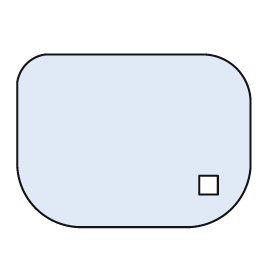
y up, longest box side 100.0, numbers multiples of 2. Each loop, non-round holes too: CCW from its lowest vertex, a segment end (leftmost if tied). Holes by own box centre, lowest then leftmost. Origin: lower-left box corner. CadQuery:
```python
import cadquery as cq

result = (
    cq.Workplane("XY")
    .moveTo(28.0, 0.0)
    .lineTo(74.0, 0.0)
    .threePointArc((92.0, 8.0), (100.0, 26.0))
    .lineTo(100.0, 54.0)
    .threePointArc((94.0, 68.0), (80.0, 74.0))
    .lineTo(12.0, 74.0)
    .threePointArc((4.0, 70.0), (0.0, 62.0))
    .lineTo(0.0, 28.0)
    .threePointArc((8.0, 8.0), (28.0, 0.0))
    .close()
    .moveTo(78.0, 14.0)
    .lineTo(86.0, 14.0)
    .lineTo(86.0, 22.0)
    .lineTo(78.0, 22.0)
    .close()
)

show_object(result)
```